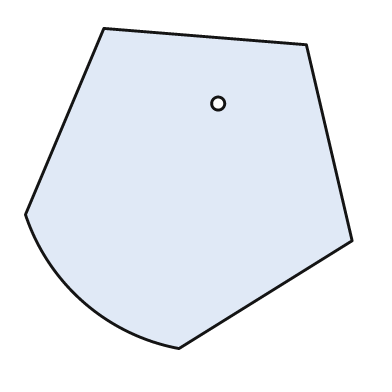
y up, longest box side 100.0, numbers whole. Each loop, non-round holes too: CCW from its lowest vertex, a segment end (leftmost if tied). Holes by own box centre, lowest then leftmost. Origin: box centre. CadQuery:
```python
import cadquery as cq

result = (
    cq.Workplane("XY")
    .moveTo(-3.0, -49.0)
    .lineTo(50.0, -16.0)
    .lineTo(36.0, 44.0)
    .lineTo(-26.0, 49.0)
    .lineTo(-50.0, -8.0)
    .threePointArc((-32.0, -35.0), (-3.0, -49.0))
    .close()
    .moveTo(9.0, 26.0)
    .circle(2.0)
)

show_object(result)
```